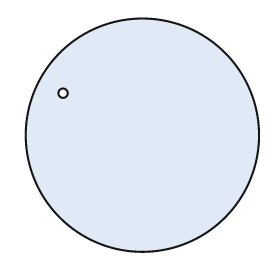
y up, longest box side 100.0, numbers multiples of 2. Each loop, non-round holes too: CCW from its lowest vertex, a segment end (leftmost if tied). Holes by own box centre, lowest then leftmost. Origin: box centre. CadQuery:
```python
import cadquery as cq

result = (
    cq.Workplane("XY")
    .moveTo(0.0, 0.0)
    .circle(50.0)
    .moveTo(-34.0, 18.0)
    .circle(2.0)
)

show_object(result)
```